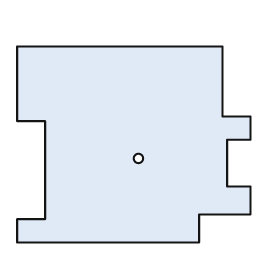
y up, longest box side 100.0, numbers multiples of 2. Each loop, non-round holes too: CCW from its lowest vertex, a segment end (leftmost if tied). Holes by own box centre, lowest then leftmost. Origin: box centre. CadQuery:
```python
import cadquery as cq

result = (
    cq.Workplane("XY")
    .moveTo(-50.0, -42.0)
    .lineTo(28.0, -42.0)
    .lineTo(28.0, -30.0)
    .lineTo(50.0, -30.0)
    .lineTo(50.0, -18.0)
    .lineTo(40.0, -18.0)
    .lineTo(40.0, 2.0)
    .lineTo(50.0, 2.0)
    .lineTo(50.0, 12.0)
    .lineTo(38.0, 12.0)
    .lineTo(38.0, 42.0)
    .lineTo(-50.0, 42.0)
    .lineTo(-50.0, 10.0)
    .lineTo(-38.0, 10.0)
    .lineTo(-38.0, -32.0)
    .lineTo(-50.0, -32.0)
    .close()
    .moveTo(2.0, -6.0)
    .circle(2.0)
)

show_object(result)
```